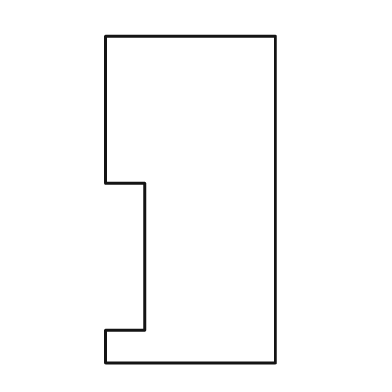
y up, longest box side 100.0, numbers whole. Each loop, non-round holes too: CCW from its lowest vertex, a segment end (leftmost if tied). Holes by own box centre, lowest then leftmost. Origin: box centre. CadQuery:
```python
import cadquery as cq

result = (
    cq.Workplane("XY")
    .moveTo(-26.0, -50.0)
    .lineTo(26.0, -50.0)
    .lineTo(26.0, 50.0)
    .lineTo(-26.0, 50.0)
    .lineTo(-26.0, 5.0)
    .lineTo(-14.0, 5.0)
    .lineTo(-14.0, -40.0)
    .lineTo(-26.0, -40.0)
    .close()
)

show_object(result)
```